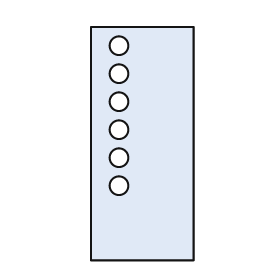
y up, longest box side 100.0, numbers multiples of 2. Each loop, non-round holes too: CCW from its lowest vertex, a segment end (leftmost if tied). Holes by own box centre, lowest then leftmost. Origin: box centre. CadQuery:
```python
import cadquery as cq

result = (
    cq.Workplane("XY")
    .moveTo(-22.0, -50.0)
    .lineTo(22.0, -50.0)
    .lineTo(22.0, 50.0)
    .lineTo(-22.0, 50.0)
    .close()
    .moveTo(-10.0, -18.0)
    .circle(4.0)
    .moveTo(-10.0, -6.0)
    .circle(4.0)
    .moveTo(-10.0, 6.0)
    .circle(4.0)
    .moveTo(-10.0, 18.0)
    .circle(4.0)
    .moveTo(-10.0, 30.0)
    .circle(4.0)
    .moveTo(-10.0, 42.0)
    .circle(4.0)
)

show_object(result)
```